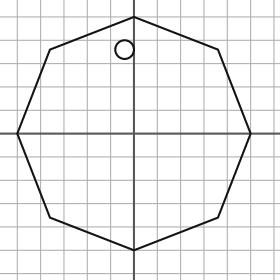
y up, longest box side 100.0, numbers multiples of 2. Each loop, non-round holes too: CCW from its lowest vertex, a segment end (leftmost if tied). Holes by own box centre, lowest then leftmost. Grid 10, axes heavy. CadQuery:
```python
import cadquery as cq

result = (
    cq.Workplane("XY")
    .moveTo(0.0, -50.0)
    .lineTo(36.0, -36.0)
    .lineTo(50.0, 0.0)
    .lineTo(36.0, 36.0)
    .lineTo(0.0, 50.0)
    .lineTo(-36.0, 36.0)
    .lineTo(-50.0, 0.0)
    .lineTo(-36.0, -36.0)
    .close()
    .moveTo(-4.0, 36.0)
    .circle(4.0)
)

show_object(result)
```